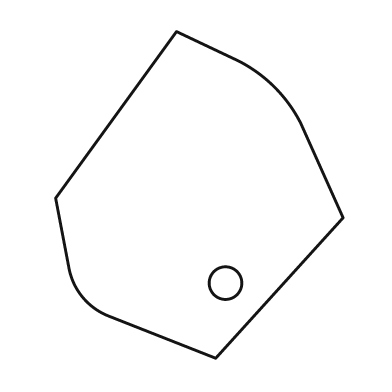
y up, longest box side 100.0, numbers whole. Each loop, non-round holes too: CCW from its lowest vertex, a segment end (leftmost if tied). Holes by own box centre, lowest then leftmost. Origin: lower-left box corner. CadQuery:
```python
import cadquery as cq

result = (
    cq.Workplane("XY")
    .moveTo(49.0, 0.0)
    .lineTo(88.0, 43.0)
    .lineTo(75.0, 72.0)
    .threePointArc((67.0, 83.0), (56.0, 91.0))
    .lineTo(37.0, 100.0)
    .lineTo(0.0, 49.0)
    .lineTo(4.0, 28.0)
    .threePointArc((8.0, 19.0), (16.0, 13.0))
    .close()
    .moveTo(52.0, 23.0)
    .circle(5.0)
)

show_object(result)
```